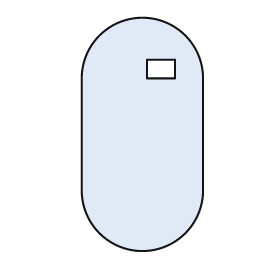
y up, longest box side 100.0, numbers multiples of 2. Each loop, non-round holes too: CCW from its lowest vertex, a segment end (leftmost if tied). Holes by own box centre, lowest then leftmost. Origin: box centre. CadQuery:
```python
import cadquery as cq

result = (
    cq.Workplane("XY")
    .moveTo(-26.0, -24.0)
    .threePointArc((0.0, -50.0), (26.0, -24.0))
    .lineTo(26.0, 24.0)
    .threePointArc((0.0, 50.0), (-26.0, 24.0))
    .close()
    .moveTo(2.0, 24.0)
    .lineTo(14.0, 24.0)
    .lineTo(14.0, 32.0)
    .lineTo(2.0, 32.0)
    .close()
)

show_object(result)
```